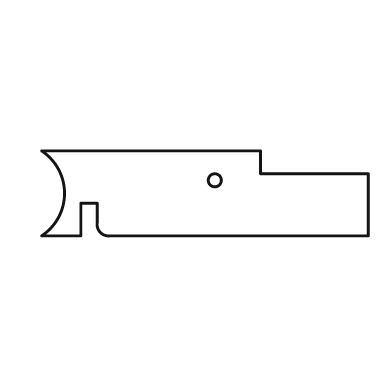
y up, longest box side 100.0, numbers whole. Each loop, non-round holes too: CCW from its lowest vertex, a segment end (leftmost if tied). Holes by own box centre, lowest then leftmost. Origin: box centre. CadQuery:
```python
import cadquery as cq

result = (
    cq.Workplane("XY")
    .moveTo(-50.0, -13.0)
    .lineTo(-38.0, -13.0)
    .lineTo(-38.0, -3.0)
    .lineTo(-33.0, -3.0)
    .lineTo(-33.0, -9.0)
    .threePointArc((-32.0, -12.0), (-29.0, -13.0))
    .lineTo(50.0, -13.0)
    .lineTo(50.0, 6.0)
    .lineTo(17.0, 6.0)
    .lineTo(17.0, 13.0)
    .lineTo(-50.0, 13.0)
    .threePointArc((-43.0, 0.0), (-50.0, -13.0))
    .close()
    .moveTo(3.0, 4.0)
    .circle(2.0)
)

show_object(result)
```